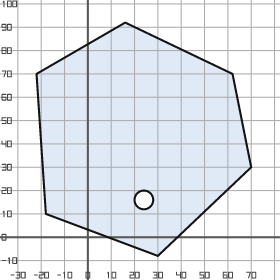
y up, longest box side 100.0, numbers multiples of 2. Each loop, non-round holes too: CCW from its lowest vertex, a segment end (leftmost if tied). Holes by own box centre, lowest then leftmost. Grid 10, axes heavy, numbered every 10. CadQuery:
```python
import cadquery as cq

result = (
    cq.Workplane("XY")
    .moveTo(30.0, -8.0)
    .lineTo(70.0, 30.0)
    .lineTo(62.0, 70.0)
    .lineTo(16.0, 92.0)
    .lineTo(-22.0, 70.0)
    .lineTo(-18.0, 10.0)
    .close()
    .moveTo(24.0, 16.0)
    .circle(4.0)
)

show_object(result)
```